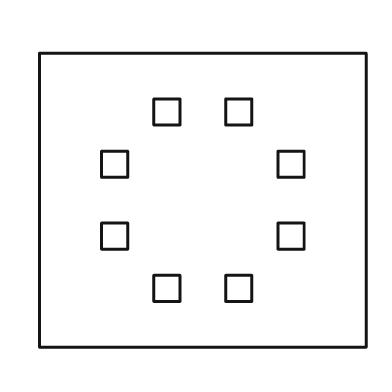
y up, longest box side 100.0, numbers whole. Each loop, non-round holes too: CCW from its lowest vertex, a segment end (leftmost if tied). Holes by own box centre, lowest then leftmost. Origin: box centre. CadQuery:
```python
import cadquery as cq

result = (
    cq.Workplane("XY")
    .moveTo(-50.0, -45.0)
    .lineTo(50.0, -45.0)
    .lineTo(50.0, 45.0)
    .lineTo(-50.0, 45.0)
    .close()
    .moveTo(-15.0, -31.0)
    .lineTo(-7.0, -31.0)
    .lineTo(-7.0, -23.0)
    .lineTo(-15.0, -23.0)
    .close()
    .moveTo(7.0, -31.0)
    .lineTo(15.0, -31.0)
    .lineTo(15.0, -23.0)
    .lineTo(7.0, -23.0)
    .close()
    .moveTo(-31.0, -15.0)
    .lineTo(-23.0, -15.0)
    .lineTo(-23.0, -7.0)
    .lineTo(-31.0, -7.0)
    .close()
    .moveTo(23.0, -15.0)
    .lineTo(31.0, -15.0)
    .lineTo(31.0, -7.0)
    .lineTo(23.0, -7.0)
    .close()
    .moveTo(-31.0, 7.0)
    .lineTo(-23.0, 7.0)
    .lineTo(-23.0, 15.0)
    .lineTo(-31.0, 15.0)
    .close()
    .moveTo(23.0, 7.0)
    .lineTo(31.0, 7.0)
    .lineTo(31.0, 15.0)
    .lineTo(23.0, 15.0)
    .close()
    .moveTo(-15.0, 23.0)
    .lineTo(-7.0, 23.0)
    .lineTo(-7.0, 31.0)
    .lineTo(-15.0, 31.0)
    .close()
    .moveTo(7.0, 23.0)
    .lineTo(15.0, 23.0)
    .lineTo(15.0, 31.0)
    .lineTo(7.0, 31.0)
    .close()
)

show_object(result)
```